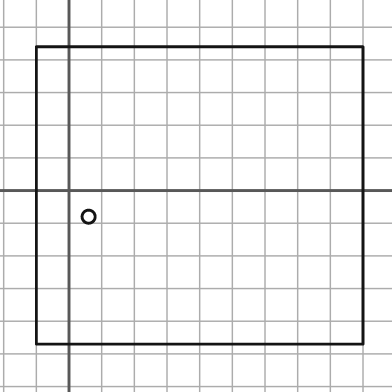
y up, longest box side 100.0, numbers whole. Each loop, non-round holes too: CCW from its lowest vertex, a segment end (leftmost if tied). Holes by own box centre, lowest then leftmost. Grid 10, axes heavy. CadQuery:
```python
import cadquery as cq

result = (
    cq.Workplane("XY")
    .moveTo(-10.0, -47.0)
    .lineTo(90.0, -47.0)
    .lineTo(90.0, 44.0)
    .lineTo(-10.0, 44.0)
    .close()
    .moveTo(6.0, -8.0)
    .circle(2.0)
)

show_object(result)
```